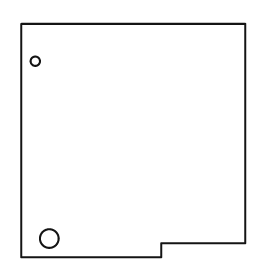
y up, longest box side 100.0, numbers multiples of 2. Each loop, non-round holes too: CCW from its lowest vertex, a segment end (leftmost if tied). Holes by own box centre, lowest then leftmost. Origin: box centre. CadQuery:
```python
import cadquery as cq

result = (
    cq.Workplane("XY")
    .moveTo(-48.0, -50.0)
    .lineTo(12.0, -50.0)
    .lineTo(12.0, -44.0)
    .lineTo(48.0, -44.0)
    .lineTo(48.0, 50.0)
    .lineTo(-48.0, 50.0)
    .close()
    .moveTo(-36.0, -42.0)
    .circle(4.0)
    .moveTo(-42.0, 34.0)
    .circle(2.0)
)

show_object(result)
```